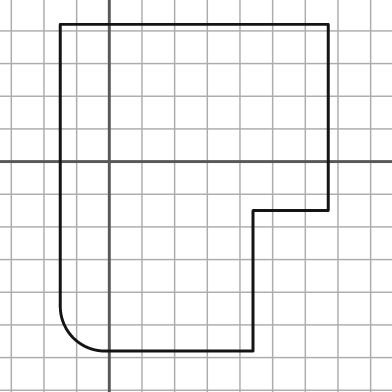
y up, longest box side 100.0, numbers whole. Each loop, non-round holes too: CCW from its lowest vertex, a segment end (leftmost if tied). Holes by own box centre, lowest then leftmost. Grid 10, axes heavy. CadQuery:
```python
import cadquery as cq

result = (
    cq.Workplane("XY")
    .moveTo(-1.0, -58.0)
    .lineTo(44.0, -58.0)
    .lineTo(44.0, -15.0)
    .lineTo(67.0, -15.0)
    .lineTo(67.0, 42.0)
    .lineTo(-15.0, 42.0)
    .lineTo(-15.0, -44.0)
    .threePointArc((-11.0, -54.0), (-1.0, -58.0))
    .close()
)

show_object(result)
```